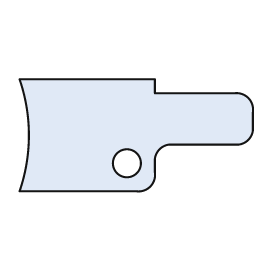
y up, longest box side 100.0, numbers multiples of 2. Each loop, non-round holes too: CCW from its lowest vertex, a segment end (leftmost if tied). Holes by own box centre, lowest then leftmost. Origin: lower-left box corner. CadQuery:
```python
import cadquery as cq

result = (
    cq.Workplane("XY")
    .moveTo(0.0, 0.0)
    .lineTo(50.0, 0.0)
    .threePointArc((56.0, 2.0), (58.0, 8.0))
    .lineTo(58.0, 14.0)
    .threePointArc((60.0, 18.0), (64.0, 20.0))
    .lineTo(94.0, 20.0)
    .threePointArc((98.0, 22.0), (100.0, 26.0))
    .lineTo(100.0, 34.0)
    .threePointArc((98.0, 40.0), (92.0, 42.0))
    .lineTo(58.0, 42.0)
    .lineTo(58.0, 48.0)
    .lineTo(0.0, 48.0)
    .threePointArc((4.0, 24.0), (0.0, 0.0))
    .close()
    .moveTo(46.0, 12.0)
    .circle(6.0)
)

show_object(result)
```